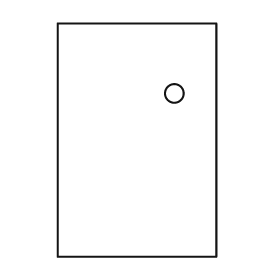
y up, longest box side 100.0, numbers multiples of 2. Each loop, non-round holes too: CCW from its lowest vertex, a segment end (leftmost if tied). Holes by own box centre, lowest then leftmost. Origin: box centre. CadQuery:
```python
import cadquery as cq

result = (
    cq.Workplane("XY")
    .moveTo(-34.0, -50.0)
    .lineTo(34.0, -50.0)
    .lineTo(34.0, 50.0)
    .lineTo(-34.0, 50.0)
    .close()
    .moveTo(16.0, 20.0)
    .circle(4.0)
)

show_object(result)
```